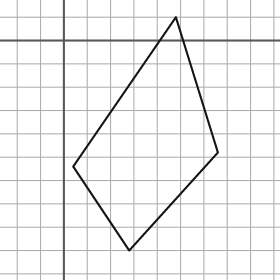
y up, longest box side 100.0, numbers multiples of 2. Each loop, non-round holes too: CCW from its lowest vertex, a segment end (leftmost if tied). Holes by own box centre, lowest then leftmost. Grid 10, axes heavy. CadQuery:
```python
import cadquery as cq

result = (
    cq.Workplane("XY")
    .moveTo(28.0, -90.0)
    .lineTo(66.0, -48.0)
    .lineTo(48.0, 10.0)
    .lineTo(4.0, -54.0)
    .close()
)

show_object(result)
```